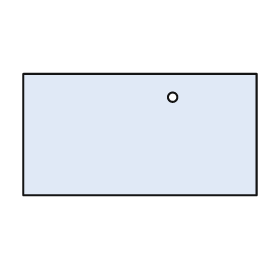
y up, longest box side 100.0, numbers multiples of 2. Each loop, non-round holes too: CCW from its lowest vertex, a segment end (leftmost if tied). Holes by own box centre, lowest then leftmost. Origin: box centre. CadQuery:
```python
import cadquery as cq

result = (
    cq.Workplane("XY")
    .moveTo(-50.0, -26.0)
    .lineTo(50.0, -26.0)
    .lineTo(50.0, 26.0)
    .lineTo(-50.0, 26.0)
    .close()
    .moveTo(14.0, 16.0)
    .circle(2.0)
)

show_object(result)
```